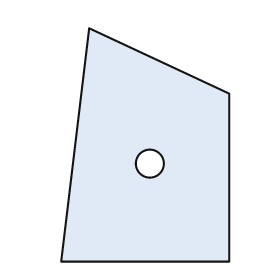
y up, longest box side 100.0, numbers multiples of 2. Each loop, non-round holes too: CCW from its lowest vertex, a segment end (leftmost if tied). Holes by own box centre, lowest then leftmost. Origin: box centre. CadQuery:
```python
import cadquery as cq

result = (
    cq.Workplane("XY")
    .moveTo(-36.0, -50.0)
    .lineTo(36.0, -50.0)
    .lineTo(36.0, 22.0)
    .lineTo(-24.0, 50.0)
    .close()
    .moveTo(2.0, -8.0)
    .circle(6.0)
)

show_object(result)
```